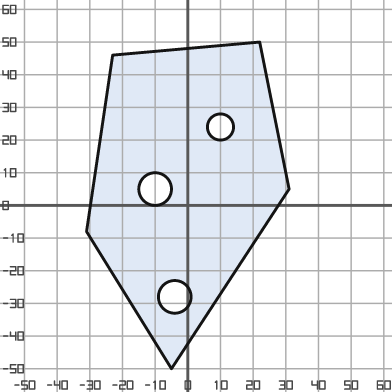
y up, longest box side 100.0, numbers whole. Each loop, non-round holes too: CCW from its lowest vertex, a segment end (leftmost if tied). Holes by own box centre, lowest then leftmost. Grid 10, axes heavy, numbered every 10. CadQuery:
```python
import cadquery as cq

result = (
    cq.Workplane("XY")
    .moveTo(-5.0, -50.0)
    .lineTo(31.0, 5.0)
    .lineTo(22.0, 50.0)
    .lineTo(-23.0, 46.0)
    .lineTo(-31.0, -8.0)
    .close()
    .moveTo(-4.0, -28.0)
    .circle(5.0)
    .moveTo(-10.0, 5.0)
    .circle(5.0)
    .moveTo(10.0, 24.0)
    .circle(4.0)
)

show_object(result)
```